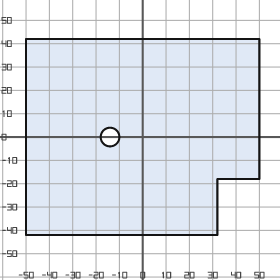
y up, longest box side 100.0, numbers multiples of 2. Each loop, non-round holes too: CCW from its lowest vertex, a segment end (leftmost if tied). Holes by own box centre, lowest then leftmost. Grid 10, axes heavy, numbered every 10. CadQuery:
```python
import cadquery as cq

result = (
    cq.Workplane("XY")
    .moveTo(-50.0, -42.0)
    .lineTo(32.0, -42.0)
    .lineTo(32.0, -18.0)
    .lineTo(50.0, -18.0)
    .lineTo(50.0, 42.0)
    .lineTo(-50.0, 42.0)
    .close()
    .moveTo(-14.0, 0.0)
    .circle(4.0)
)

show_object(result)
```